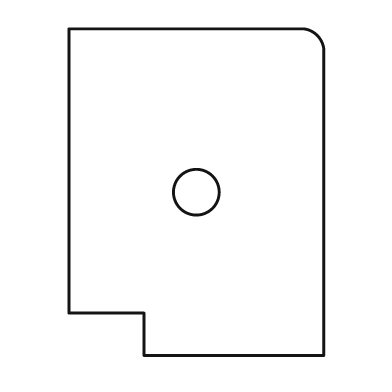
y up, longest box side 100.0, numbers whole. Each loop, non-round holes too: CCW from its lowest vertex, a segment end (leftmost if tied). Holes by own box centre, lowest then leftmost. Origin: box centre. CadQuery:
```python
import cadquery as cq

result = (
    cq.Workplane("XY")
    .moveTo(-16.0, -50.0)
    .lineTo(39.0, -50.0)
    .lineTo(39.0, 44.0)
    .threePointArc((37.0, 48.0), (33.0, 50.0))
    .lineTo(-39.0, 50.0)
    .lineTo(-39.0, -37.0)
    .lineTo(-16.0, -37.0)
    .close()
    .moveTo(0.0, 0.0)
    .circle(7.0)
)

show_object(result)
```